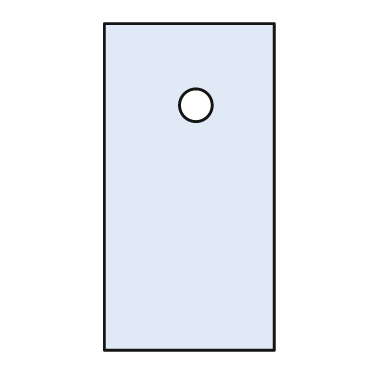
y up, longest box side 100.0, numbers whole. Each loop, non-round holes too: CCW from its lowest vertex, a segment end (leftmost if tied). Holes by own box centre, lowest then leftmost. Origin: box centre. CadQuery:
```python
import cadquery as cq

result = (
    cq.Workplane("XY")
    .moveTo(-26.0, -50.0)
    .lineTo(26.0, -50.0)
    .lineTo(26.0, 50.0)
    .lineTo(-26.0, 50.0)
    .close()
    .moveTo(2.0, 25.0)
    .circle(5.0)
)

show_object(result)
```